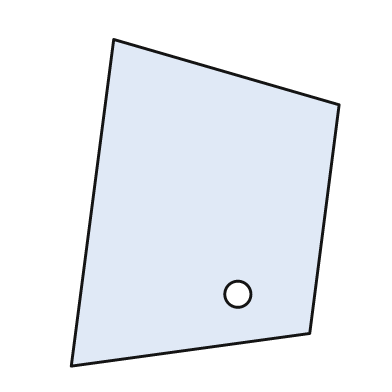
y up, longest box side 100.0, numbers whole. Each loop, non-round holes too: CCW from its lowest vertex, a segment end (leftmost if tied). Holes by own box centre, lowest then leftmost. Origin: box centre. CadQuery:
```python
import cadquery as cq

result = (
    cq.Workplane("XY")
    .moveTo(-41.0, -50.0)
    .lineTo(32.0, -40.0)
    .lineTo(41.0, 30.0)
    .lineTo(-28.0, 50.0)
    .close()
    .moveTo(10.0, -28.0)
    .circle(4.0)
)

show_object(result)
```